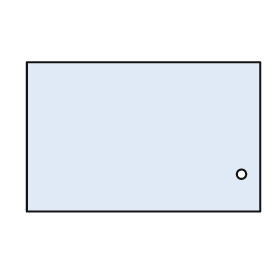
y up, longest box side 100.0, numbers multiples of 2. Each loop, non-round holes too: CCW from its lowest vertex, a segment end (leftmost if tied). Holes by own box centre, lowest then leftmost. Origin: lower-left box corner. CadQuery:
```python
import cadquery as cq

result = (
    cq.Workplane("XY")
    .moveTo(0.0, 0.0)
    .lineTo(100.0, 0.0)
    .lineTo(100.0, 64.0)
    .lineTo(0.0, 64.0)
    .close()
    .moveTo(92.0, 16.0)
    .circle(2.0)
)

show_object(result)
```